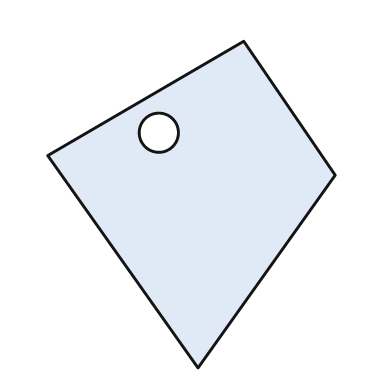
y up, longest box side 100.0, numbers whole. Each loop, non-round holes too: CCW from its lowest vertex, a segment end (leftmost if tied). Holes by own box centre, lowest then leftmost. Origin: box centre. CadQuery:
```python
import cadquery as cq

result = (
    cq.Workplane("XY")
    .moveTo(2.0, -50.0)
    .lineTo(44.0, 9.0)
    .lineTo(16.0, 50.0)
    .lineTo(-44.0, 15.0)
    .close()
    .moveTo(-10.0, 22.0)
    .circle(6.0)
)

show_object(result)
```